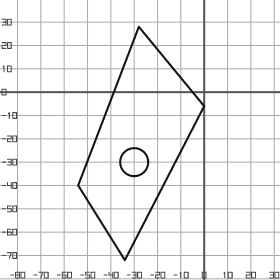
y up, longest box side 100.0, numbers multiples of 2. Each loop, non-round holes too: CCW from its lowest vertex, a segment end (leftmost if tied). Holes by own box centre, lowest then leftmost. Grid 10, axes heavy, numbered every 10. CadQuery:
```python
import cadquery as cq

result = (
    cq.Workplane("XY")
    .moveTo(-34.0, -72.0)
    .lineTo(0.0, -6.0)
    .lineTo(-28.0, 28.0)
    .lineTo(-54.0, -40.0)
    .close()
    .moveTo(-30.0, -30.0)
    .circle(6.0)
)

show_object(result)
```